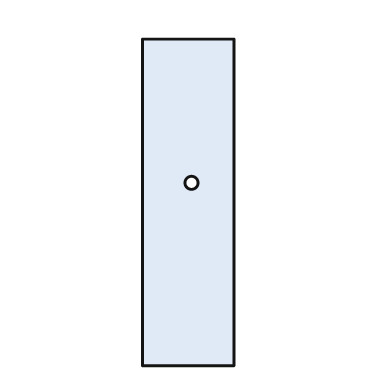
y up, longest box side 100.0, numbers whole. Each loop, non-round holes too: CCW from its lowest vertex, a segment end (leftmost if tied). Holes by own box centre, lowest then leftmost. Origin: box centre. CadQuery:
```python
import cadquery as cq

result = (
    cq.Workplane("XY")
    .moveTo(-14.0, -50.0)
    .lineTo(14.0, -50.0)
    .lineTo(14.0, 50.0)
    .lineTo(-14.0, 50.0)
    .close()
    .moveTo(1.0, 6.0)
    .circle(2.0)
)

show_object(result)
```